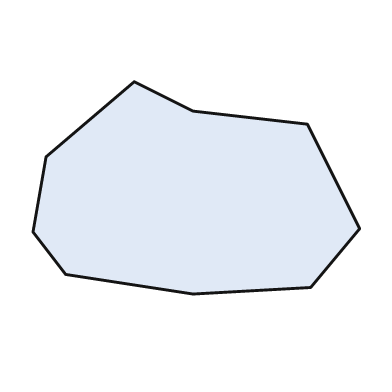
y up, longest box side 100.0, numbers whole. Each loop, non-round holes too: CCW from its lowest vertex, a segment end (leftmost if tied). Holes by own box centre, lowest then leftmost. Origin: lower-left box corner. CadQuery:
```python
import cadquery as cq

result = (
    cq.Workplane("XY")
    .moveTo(49.0, 0.0)
    .lineTo(85.0, 2.0)
    .lineTo(100.0, 20.0)
    .lineTo(84.0, 52.0)
    .lineTo(49.0, 56.0)
    .lineTo(31.0, 65.0)
    .lineTo(4.0, 42.0)
    .lineTo(0.0, 19.0)
    .lineTo(10.0, 6.0)
    .close()
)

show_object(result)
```